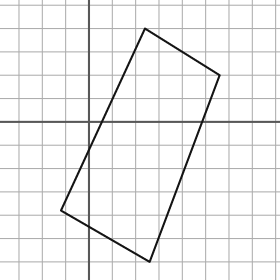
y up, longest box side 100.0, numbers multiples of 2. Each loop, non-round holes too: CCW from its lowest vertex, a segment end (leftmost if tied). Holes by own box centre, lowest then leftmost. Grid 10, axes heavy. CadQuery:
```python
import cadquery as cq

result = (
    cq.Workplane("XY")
    .moveTo(26.0, -60.0)
    .lineTo(56.0, 20.0)
    .lineTo(24.0, 40.0)
    .lineTo(-12.0, -38.0)
    .close()
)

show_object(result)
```